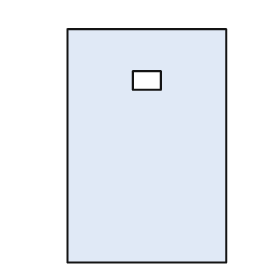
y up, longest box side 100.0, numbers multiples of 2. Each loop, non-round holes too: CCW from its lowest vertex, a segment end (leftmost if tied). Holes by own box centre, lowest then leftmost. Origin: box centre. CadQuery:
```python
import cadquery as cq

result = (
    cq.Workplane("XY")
    .moveTo(-34.0, -50.0)
    .lineTo(34.0, -50.0)
    .lineTo(34.0, 50.0)
    .lineTo(-34.0, 50.0)
    .close()
    .moveTo(-6.0, 24.0)
    .lineTo(6.0, 24.0)
    .lineTo(6.0, 32.0)
    .lineTo(-6.0, 32.0)
    .close()
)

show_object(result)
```